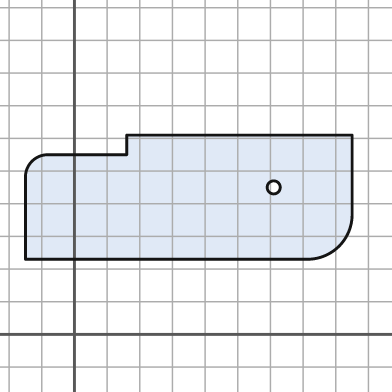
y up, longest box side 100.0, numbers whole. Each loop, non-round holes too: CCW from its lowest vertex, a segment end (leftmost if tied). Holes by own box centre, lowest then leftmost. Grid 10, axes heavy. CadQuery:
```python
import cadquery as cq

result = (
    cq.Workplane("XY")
    .moveTo(-15.0, 23.0)
    .lineTo(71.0, 23.0)
    .threePointArc((81.0, 27.0), (85.0, 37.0))
    .lineTo(85.0, 61.0)
    .lineTo(16.0, 61.0)
    .lineTo(16.0, 55.0)
    .lineTo(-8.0, 55.0)
    .threePointArc((-13.0, 53.0), (-15.0, 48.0))
    .close()
    .moveTo(61.0, 45.0)
    .circle(2.0)
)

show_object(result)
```